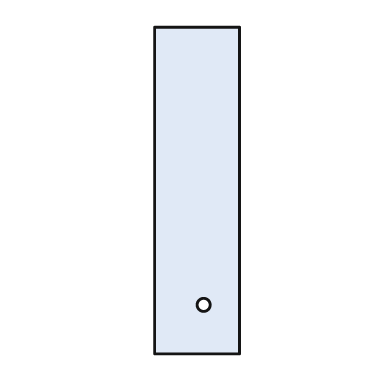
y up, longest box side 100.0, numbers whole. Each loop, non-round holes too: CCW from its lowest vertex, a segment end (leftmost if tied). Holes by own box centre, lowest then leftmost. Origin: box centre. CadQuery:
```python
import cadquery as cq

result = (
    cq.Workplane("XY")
    .moveTo(-13.0, -50.0)
    .lineTo(13.0, -50.0)
    .lineTo(13.0, 50.0)
    .lineTo(-13.0, 50.0)
    .close()
    .moveTo(2.0, -35.0)
    .circle(2.0)
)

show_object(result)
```